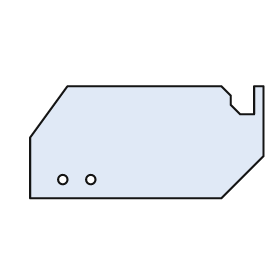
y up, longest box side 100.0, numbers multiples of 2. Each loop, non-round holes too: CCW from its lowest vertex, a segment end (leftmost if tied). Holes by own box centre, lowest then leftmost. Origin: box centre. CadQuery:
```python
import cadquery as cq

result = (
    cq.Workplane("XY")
    .moveTo(-50.0, -24.0)
    .lineTo(32.0, -24.0)
    .lineTo(50.0, -6.0)
    .lineTo(50.0, 24.0)
    .lineTo(46.0, 24.0)
    .lineTo(46.0, 12.0)
    .lineTo(40.0, 12.0)
    .lineTo(36.0, 16.0)
    .lineTo(36.0, 20.0)
    .lineTo(32.0, 24.0)
    .lineTo(-34.0, 24.0)
    .lineTo(-50.0, 2.0)
    .close()
    .moveTo(-36.0, -16.0)
    .circle(2.0)
    .moveTo(-24.0, -16.0)
    .circle(2.0)
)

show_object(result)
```